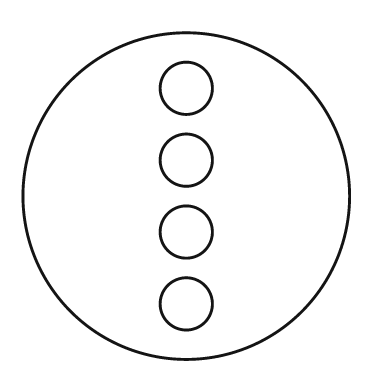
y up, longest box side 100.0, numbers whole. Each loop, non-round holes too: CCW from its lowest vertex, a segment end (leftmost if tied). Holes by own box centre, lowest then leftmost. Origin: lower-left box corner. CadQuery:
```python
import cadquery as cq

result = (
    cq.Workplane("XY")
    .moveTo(50.0, 50.0)
    .circle(50.0)
    .moveTo(50.0, 17.0)
    .circle(8.0)
    .moveTo(50.0, 39.0)
    .circle(8.0)
    .moveTo(50.0, 61.0)
    .circle(8.0)
    .moveTo(50.0, 83.0)
    .circle(8.0)
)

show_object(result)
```